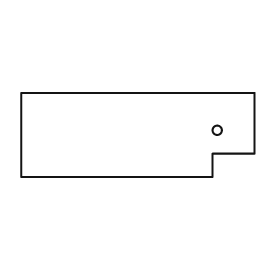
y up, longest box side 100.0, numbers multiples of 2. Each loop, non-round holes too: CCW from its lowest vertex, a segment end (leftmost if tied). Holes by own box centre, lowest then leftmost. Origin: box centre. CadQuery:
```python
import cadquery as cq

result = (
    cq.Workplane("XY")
    .moveTo(-50.0, -18.0)
    .lineTo(32.0, -18.0)
    .lineTo(32.0, -8.0)
    .lineTo(50.0, -8.0)
    .lineTo(50.0, 18.0)
    .lineTo(-50.0, 18.0)
    .close()
    .moveTo(34.0, 2.0)
    .circle(2.0)
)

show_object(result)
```